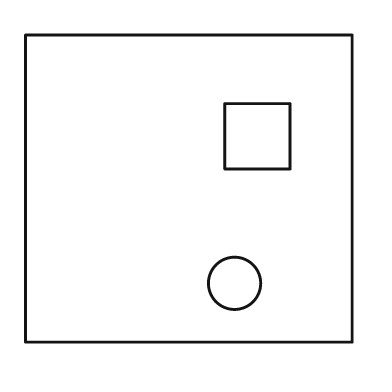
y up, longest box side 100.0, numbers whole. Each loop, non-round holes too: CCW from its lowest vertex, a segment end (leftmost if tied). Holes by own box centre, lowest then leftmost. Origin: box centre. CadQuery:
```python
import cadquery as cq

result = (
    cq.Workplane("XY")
    .moveTo(-50.0, -47.0)
    .lineTo(50.0, -47.0)
    .lineTo(50.0, 47.0)
    .lineTo(-50.0, 47.0)
    .close()
    .moveTo(14.0, -29.0)
    .circle(8.0)
    .moveTo(11.0, 6.0)
    .lineTo(31.0, 6.0)
    .lineTo(31.0, 26.0)
    .lineTo(11.0, 26.0)
    .close()
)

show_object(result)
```